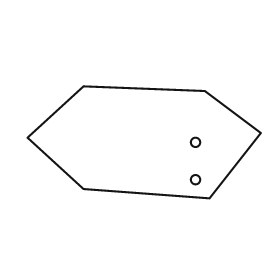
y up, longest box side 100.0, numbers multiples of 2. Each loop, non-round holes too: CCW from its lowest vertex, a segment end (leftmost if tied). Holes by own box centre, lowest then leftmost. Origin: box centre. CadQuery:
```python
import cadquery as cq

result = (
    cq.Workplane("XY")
    .moveTo(28.0, -24.0)
    .lineTo(50.0, 4.0)
    .lineTo(26.0, 22.0)
    .lineTo(-26.0, 24.0)
    .lineTo(-50.0, 2.0)
    .lineTo(-26.0, -20.0)
    .close()
    .moveTo(22.0, -16.0)
    .circle(2.0)
    .moveTo(22.0, 0.0)
    .circle(2.0)
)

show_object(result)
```